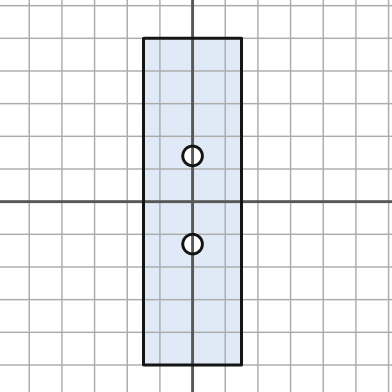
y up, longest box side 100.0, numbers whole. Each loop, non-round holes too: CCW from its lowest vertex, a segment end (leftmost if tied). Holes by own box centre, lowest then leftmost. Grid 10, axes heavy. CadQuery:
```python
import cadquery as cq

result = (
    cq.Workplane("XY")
    .moveTo(-15.0, -50.0)
    .lineTo(15.0, -50.0)
    .lineTo(15.0, 50.0)
    .lineTo(-15.0, 50.0)
    .close()
    .moveTo(0.0, -13.0)
    .circle(3.0)
    .moveTo(0.0, 14.0)
    .circle(3.0)
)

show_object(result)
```